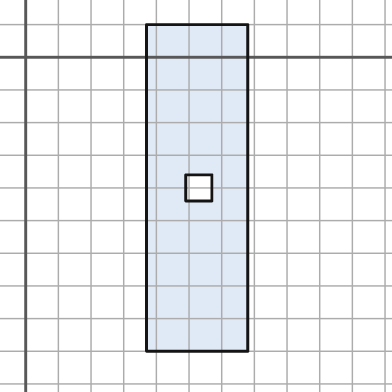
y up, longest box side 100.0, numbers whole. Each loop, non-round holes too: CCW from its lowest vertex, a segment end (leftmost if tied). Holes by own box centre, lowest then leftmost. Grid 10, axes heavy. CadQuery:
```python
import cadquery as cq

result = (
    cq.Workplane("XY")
    .moveTo(37.0, -90.0)
    .lineTo(68.0, -90.0)
    .lineTo(68.0, 10.0)
    .lineTo(37.0, 10.0)
    .close()
    .moveTo(49.0, -44.0)
    .lineTo(57.0, -44.0)
    .lineTo(57.0, -36.0)
    .lineTo(49.0, -36.0)
    .close()
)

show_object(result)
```